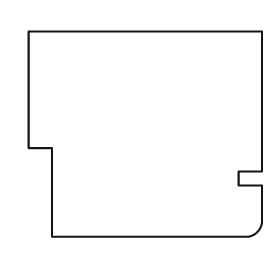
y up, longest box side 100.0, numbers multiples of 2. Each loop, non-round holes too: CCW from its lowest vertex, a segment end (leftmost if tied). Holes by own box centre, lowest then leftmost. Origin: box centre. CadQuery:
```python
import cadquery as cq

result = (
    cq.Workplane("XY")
    .moveTo(-40.0, -44.0)
    .lineTo(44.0, -44.0)
    .threePointArc((48.0, -42.0), (50.0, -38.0))
    .lineTo(50.0, -22.0)
    .lineTo(40.0, -22.0)
    .lineTo(40.0, -16.0)
    .lineTo(50.0, -16.0)
    .lineTo(50.0, 44.0)
    .lineTo(-50.0, 44.0)
    .lineTo(-50.0, -6.0)
    .lineTo(-40.0, -6.0)
    .close()
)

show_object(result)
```